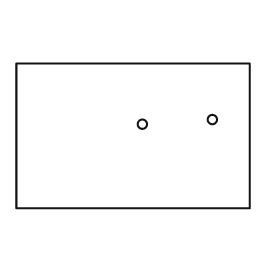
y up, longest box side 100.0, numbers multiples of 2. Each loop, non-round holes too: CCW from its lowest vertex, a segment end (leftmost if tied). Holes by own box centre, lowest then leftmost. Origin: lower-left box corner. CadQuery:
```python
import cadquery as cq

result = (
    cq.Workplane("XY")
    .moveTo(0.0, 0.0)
    .lineTo(100.0, 0.0)
    .lineTo(100.0, 62.0)
    .lineTo(0.0, 62.0)
    .close()
    .moveTo(54.0, 36.0)
    .circle(2.0)
    .moveTo(84.0, 38.0)
    .circle(2.0)
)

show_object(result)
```